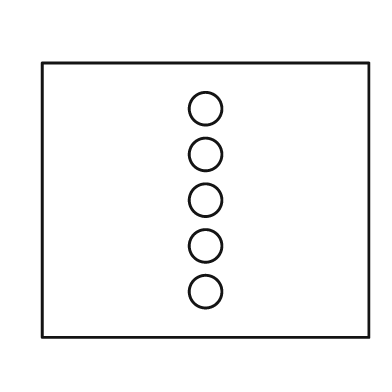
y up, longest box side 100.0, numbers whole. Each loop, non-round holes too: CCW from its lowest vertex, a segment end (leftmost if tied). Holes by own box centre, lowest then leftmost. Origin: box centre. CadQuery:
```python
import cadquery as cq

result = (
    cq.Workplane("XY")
    .moveTo(-50.0, -42.0)
    .lineTo(50.0, -42.0)
    .lineTo(50.0, 42.0)
    .lineTo(-50.0, 42.0)
    .close()
    .moveTo(0.0, -28.0)
    .circle(5.0)
    .moveTo(0.0, -14.0)
    .circle(5.0)
    .moveTo(0.0, 0.0)
    .circle(5.0)
    .moveTo(0.0, 14.0)
    .circle(5.0)
    .moveTo(0.0, 28.0)
    .circle(5.0)
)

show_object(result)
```